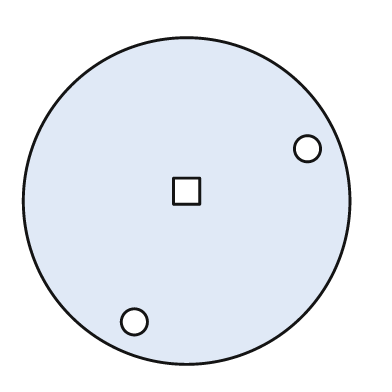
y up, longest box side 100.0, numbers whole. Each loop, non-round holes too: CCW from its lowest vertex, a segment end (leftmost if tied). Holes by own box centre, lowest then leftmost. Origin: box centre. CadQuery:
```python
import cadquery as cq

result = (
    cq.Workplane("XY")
    .moveTo(0.0, 0.0)
    .circle(50.0)
    .moveTo(-16.0, -37.0)
    .circle(4.0)
    .moveTo(-4.0, -1.0)
    .lineTo(4.0, -1.0)
    .lineTo(4.0, 7.0)
    .lineTo(-4.0, 7.0)
    .close()
    .moveTo(37.0, 16.0)
    .circle(4.0)
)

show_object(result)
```